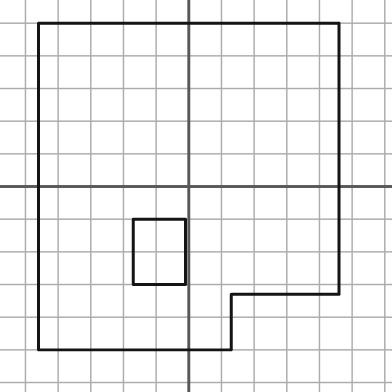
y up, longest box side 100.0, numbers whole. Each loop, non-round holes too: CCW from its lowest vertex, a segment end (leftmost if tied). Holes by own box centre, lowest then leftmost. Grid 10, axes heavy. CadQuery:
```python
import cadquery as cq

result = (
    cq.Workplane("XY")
    .moveTo(-46.0, -50.0)
    .lineTo(13.0, -50.0)
    .lineTo(13.0, -33.0)
    .lineTo(46.0, -33.0)
    .lineTo(46.0, 50.0)
    .lineTo(-46.0, 50.0)
    .close()
    .moveTo(-17.0, -30.0)
    .lineTo(-1.0, -30.0)
    .lineTo(-1.0, -10.0)
    .lineTo(-17.0, -10.0)
    .close()
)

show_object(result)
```